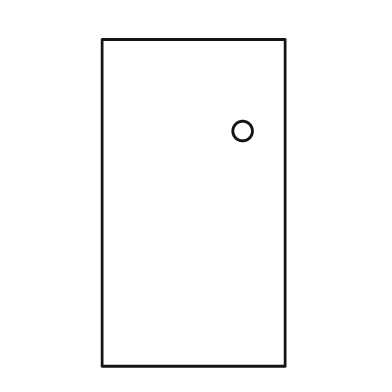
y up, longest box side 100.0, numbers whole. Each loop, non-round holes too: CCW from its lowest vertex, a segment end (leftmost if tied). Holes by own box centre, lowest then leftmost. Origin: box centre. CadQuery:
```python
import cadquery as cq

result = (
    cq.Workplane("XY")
    .moveTo(-28.0, -50.0)
    .lineTo(28.0, -50.0)
    .lineTo(28.0, 50.0)
    .lineTo(-28.0, 50.0)
    .close()
    .moveTo(15.0, 22.0)
    .circle(3.0)
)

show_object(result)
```